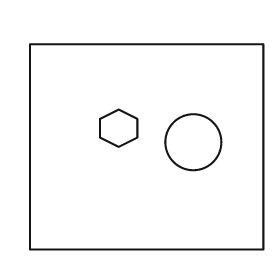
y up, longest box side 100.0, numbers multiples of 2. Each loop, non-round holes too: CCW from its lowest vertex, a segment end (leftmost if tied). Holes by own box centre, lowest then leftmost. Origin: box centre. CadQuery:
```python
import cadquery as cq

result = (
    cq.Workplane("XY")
    .moveTo(-50.0, -44.0)
    .lineTo(50.0, -44.0)
    .lineTo(50.0, 44.0)
    .lineTo(-50.0, 44.0)
    .close()
    .moveTo(20.0, 2.0)
    .circle(12.0)
    .moveTo(-12.0, 0.0)
    .lineTo(-4.0, 4.0)
    .lineTo(-4.0, 12.0)
    .lineTo(-12.0, 16.0)
    .lineTo(-20.0, 12.0)
    .lineTo(-20.0, 4.0)
    .close()
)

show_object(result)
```